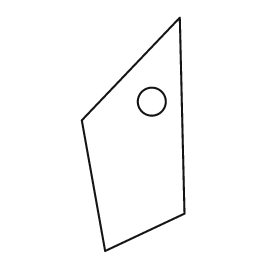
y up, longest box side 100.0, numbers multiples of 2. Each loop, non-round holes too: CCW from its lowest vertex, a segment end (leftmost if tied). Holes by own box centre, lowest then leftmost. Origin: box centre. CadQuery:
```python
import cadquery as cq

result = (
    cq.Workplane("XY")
    .moveTo(-12.0, -50.0)
    .lineTo(22.0, -34.0)
    .lineTo(20.0, 50.0)
    .lineTo(-22.0, 6.0)
    .close()
    .moveTo(8.0, 14.0)
    .circle(6.0)
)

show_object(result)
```